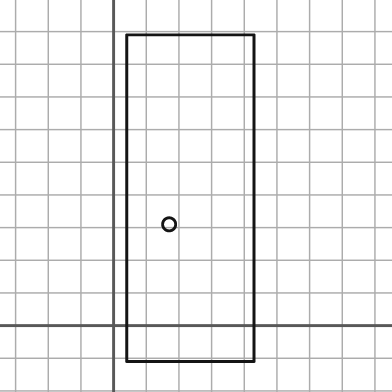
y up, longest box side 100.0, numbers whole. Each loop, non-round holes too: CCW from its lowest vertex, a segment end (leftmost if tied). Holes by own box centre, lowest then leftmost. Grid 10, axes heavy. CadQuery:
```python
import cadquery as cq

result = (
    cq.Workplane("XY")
    .moveTo(4.0, -11.0)
    .lineTo(43.0, -11.0)
    .lineTo(43.0, 89.0)
    .lineTo(4.0, 89.0)
    .close()
    .moveTo(17.0, 31.0)
    .circle(2.0)
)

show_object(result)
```